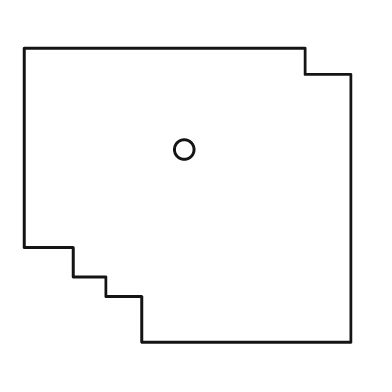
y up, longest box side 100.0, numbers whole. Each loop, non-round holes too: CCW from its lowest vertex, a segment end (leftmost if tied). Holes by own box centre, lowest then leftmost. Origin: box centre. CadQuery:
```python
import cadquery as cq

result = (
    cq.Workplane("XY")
    .moveTo(-14.0, -45.0)
    .lineTo(50.0, -45.0)
    .lineTo(50.0, 37.0)
    .lineTo(36.0, 37.0)
    .lineTo(36.0, 45.0)
    .lineTo(-50.0, 45.0)
    .lineTo(-50.0, -16.0)
    .lineTo(-35.0, -16.0)
    .lineTo(-35.0, -25.0)
    .lineTo(-25.0, -25.0)
    .lineTo(-25.0, -31.0)
    .lineTo(-14.0, -31.0)
    .close()
    .moveTo(-1.0, 14.0)
    .circle(3.0)
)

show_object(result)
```